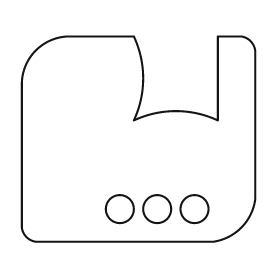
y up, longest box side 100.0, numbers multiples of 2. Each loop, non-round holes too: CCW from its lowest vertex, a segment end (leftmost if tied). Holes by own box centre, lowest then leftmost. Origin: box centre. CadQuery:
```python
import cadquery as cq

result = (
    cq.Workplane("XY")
    .moveTo(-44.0, -44.0)
    .lineTo(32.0, -44.0)
    .threePointArc((44.0, -38.0), (50.0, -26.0))
    .lineTo(50.0, 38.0)
    .threePointArc((48.0, 42.0), (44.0, 44.0))
    .lineTo(34.0, 44.0)
    .lineTo(34.0, 8.0)
    .threePointArc((16.0, 12.0), (-2.0, 8.0))
    .threePointArc((2.0, 26.0), (-2.0, 44.0))
    .lineTo(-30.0, 44.0)
    .threePointArc((-44.0, 38.0), (-50.0, 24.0))
    .lineTo(-50.0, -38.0)
    .threePointArc((-48.0, -42.0), (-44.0, -44.0))
    .close()
    .moveTo(-8.0, -30.0)
    .circle(6.0)
    .moveTo(8.0, -30.0)
    .circle(6.0)
    .moveTo(24.0, -30.0)
    .circle(6.0)
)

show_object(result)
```